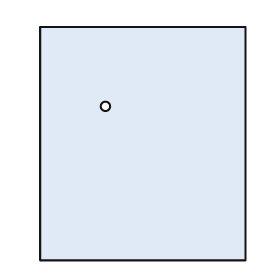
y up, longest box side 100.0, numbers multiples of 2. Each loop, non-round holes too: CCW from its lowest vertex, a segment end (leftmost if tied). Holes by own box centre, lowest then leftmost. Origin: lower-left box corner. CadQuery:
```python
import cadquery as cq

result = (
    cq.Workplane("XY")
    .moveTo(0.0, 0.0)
    .lineTo(88.0, 0.0)
    .lineTo(88.0, 100.0)
    .lineTo(0.0, 100.0)
    .close()
    .moveTo(28.0, 66.0)
    .circle(2.0)
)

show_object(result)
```